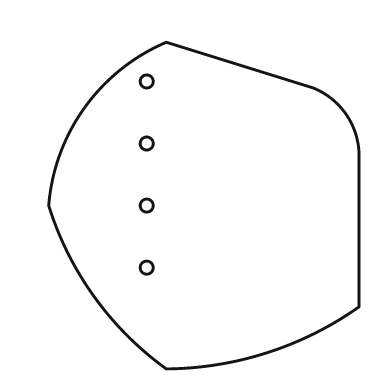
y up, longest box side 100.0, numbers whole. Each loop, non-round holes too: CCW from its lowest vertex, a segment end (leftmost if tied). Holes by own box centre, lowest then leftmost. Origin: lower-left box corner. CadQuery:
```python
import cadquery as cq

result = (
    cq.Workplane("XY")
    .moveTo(36.0, 0.0)
    .threePointArc((67.0, 5.0), (95.0, 19.0))
    .lineTo(95.0, 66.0)
    .threePointArc((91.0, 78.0), (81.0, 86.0))
    .lineTo(36.0, 100.0)
    .threePointArc((11.0, 80.0), (0.0, 50.0))
    .threePointArc((14.0, 22.0), (36.0, 0.0))
    .close()
    .moveTo(30.0, 31.0)
    .circle(2.0)
    .moveTo(30.0, 50.0)
    .circle(2.0)
    .moveTo(30.0, 69.0)
    .circle(2.0)
    .moveTo(30.0, 88.0)
    .circle(2.0)
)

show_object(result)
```